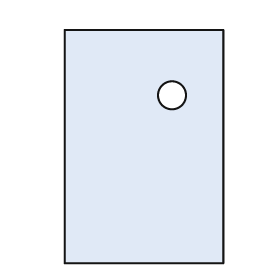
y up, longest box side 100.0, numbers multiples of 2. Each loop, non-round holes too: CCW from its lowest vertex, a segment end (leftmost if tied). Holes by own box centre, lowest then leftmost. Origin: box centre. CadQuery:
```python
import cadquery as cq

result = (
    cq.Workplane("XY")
    .moveTo(-34.0, -50.0)
    .lineTo(34.0, -50.0)
    .lineTo(34.0, 50.0)
    .lineTo(-34.0, 50.0)
    .close()
    .moveTo(12.0, 22.0)
    .circle(6.0)
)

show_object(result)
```